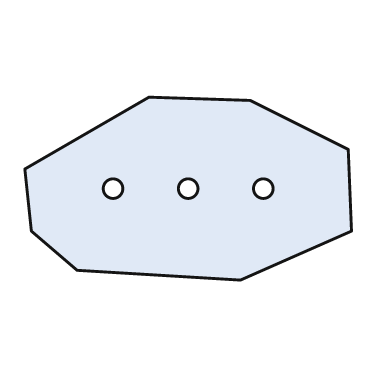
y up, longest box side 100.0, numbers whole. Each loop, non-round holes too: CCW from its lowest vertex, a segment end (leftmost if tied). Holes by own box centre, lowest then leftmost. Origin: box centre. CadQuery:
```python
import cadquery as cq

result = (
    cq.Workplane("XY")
    .moveTo(16.0, -28.0)
    .lineTo(50.0, -13.0)
    .lineTo(49.0, 12.0)
    .lineTo(19.0, 27.0)
    .lineTo(-12.0, 28.0)
    .lineTo(-50.0, 6.0)
    .lineTo(-48.0, -13.0)
    .lineTo(-34.0, -25.0)
    .close()
    .moveTo(-23.0, 0.0)
    .circle(3.0)
    .moveTo(0.0, 0.0)
    .circle(3.0)
    .moveTo(23.0, 0.0)
    .circle(3.0)
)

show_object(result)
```